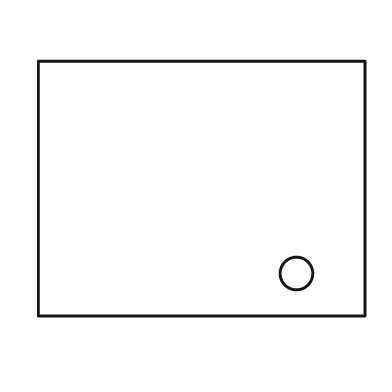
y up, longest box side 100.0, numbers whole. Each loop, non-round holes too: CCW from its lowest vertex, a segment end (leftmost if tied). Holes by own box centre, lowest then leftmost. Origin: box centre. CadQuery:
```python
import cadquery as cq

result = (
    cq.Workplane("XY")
    .moveTo(-50.0, -39.0)
    .lineTo(50.0, -39.0)
    .lineTo(50.0, 39.0)
    .lineTo(-50.0, 39.0)
    .close()
    .moveTo(29.0, -26.0)
    .circle(5.0)
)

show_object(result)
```